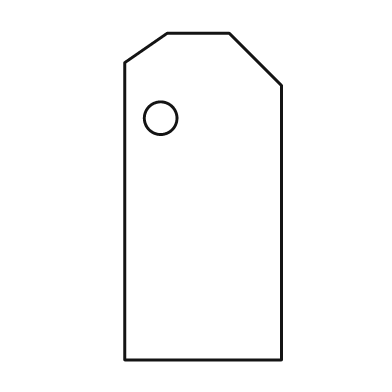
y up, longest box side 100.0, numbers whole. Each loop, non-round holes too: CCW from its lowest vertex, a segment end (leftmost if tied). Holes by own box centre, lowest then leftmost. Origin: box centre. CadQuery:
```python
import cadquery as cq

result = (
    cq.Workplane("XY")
    .moveTo(-24.0, -50.0)
    .lineTo(24.0, -50.0)
    .lineTo(24.0, 34.0)
    .lineTo(8.0, 50.0)
    .lineTo(-11.0, 50.0)
    .lineTo(-24.0, 41.0)
    .close()
    .moveTo(-13.0, 24.0)
    .circle(5.0)
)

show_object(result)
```